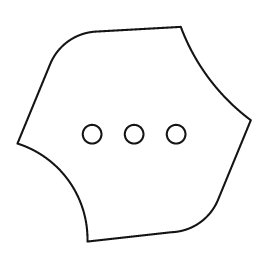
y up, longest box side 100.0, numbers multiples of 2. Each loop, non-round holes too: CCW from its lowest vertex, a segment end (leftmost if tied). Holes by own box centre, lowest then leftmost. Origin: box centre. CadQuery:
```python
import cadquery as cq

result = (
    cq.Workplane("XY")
    .moveTo(-20.0, -46.0)
    .lineTo(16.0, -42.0)
    .threePointArc((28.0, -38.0), (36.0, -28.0))
    .lineTo(50.0, 6.0)
    .threePointArc((32.0, 24.0), (20.0, 46.0))
    .lineTo(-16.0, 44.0)
    .threePointArc((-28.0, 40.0), (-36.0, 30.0))
    .lineTo(-50.0, -4.0)
    .threePointArc((-28.0, -20.0), (-20.0, -46.0))
    .close()
    .moveTo(-18.0, 0.0)
    .circle(4.0)
    .moveTo(0.0, 0.0)
    .circle(4.0)
    .moveTo(18.0, 0.0)
    .circle(4.0)
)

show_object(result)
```